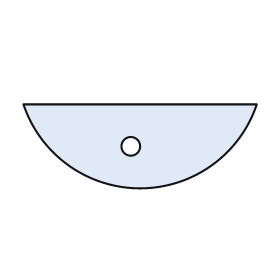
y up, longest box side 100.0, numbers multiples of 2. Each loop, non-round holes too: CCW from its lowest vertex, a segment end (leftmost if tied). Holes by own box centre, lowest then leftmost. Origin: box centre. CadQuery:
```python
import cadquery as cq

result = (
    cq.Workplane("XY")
    .moveTo(-50.0, 18.0)
    .threePointArc((0.0, -18.0), (50.0, 18.0))
    .close()
    .moveTo(-4.0, 0.0)
    .circle(4.0)
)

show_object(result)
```